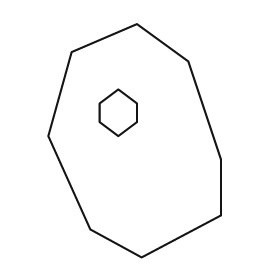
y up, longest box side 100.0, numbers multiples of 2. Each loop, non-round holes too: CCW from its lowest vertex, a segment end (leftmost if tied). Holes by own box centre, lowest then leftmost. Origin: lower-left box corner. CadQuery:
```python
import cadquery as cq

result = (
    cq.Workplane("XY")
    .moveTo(40.0, 0.0)
    .lineTo(74.0, 18.0)
    .lineTo(74.0, 42.0)
    .lineTo(60.0, 84.0)
    .lineTo(38.0, 100.0)
    .lineTo(10.0, 88.0)
    .lineTo(0.0, 52.0)
    .lineTo(18.0, 12.0)
    .close()
    .moveTo(30.0, 52.0)
    .lineTo(38.0, 58.0)
    .lineTo(38.0, 66.0)
    .lineTo(30.0, 72.0)
    .lineTo(22.0, 66.0)
    .lineTo(22.0, 58.0)
    .close()
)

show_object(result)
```